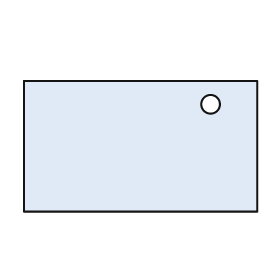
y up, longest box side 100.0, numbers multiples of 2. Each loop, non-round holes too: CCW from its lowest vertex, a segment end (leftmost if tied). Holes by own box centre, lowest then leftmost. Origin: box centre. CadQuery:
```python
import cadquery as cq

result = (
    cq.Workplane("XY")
    .moveTo(-50.0, -28.0)
    .lineTo(50.0, -28.0)
    .lineTo(50.0, 28.0)
    .lineTo(-50.0, 28.0)
    .close()
    .moveTo(30.0, 18.0)
    .circle(4.0)
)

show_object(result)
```